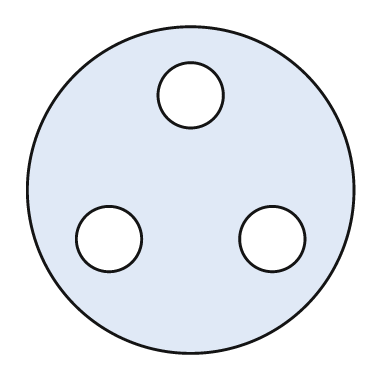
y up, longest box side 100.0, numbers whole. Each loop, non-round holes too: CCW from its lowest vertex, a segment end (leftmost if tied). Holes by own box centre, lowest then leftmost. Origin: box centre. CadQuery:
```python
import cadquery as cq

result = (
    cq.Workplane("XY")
    .moveTo(0.0, 0.0)
    .circle(50.0)
    .moveTo(-25.0, -15.0)
    .circle(10.0)
    .moveTo(25.0, -15.0)
    .circle(10.0)
    .moveTo(0.0, 29.0)
    .circle(10.0)
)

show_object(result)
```